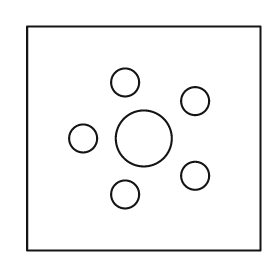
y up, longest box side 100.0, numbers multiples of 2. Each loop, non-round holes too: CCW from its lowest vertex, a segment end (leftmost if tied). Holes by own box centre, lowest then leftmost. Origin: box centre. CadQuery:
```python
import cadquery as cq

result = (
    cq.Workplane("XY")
    .moveTo(-50.0, -48.0)
    .lineTo(50.0, -48.0)
    .lineTo(50.0, 48.0)
    .lineTo(-50.0, 48.0)
    .close()
    .moveTo(-8.0, -24.0)
    .circle(6.0)
    .moveTo(22.0, -16.0)
    .circle(6.0)
    .moveTo(-26.0, 0.0)
    .circle(6.0)
    .moveTo(0.0, 0.0)
    .circle(12.0)
    .moveTo(22.0, 16.0)
    .circle(6.0)
    .moveTo(-8.0, 24.0)
    .circle(6.0)
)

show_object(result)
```